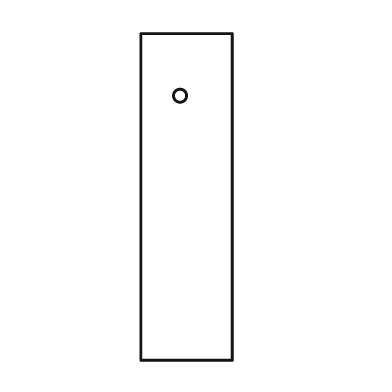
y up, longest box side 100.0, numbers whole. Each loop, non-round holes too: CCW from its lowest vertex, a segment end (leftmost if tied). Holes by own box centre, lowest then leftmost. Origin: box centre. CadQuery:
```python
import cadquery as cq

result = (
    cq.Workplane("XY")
    .moveTo(-14.0, -50.0)
    .lineTo(14.0, -50.0)
    .lineTo(14.0, 50.0)
    .lineTo(-14.0, 50.0)
    .close()
    .moveTo(-2.0, 31.0)
    .circle(2.0)
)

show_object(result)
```